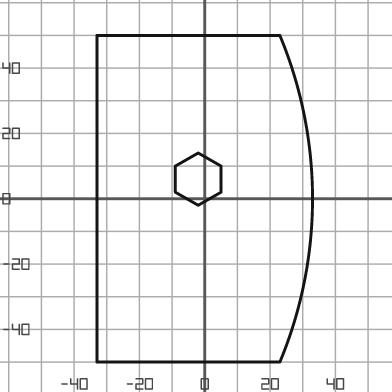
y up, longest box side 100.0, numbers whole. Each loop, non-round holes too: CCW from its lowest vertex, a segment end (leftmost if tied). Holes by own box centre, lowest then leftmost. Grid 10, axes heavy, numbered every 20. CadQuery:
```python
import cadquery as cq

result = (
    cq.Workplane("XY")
    .moveTo(-33.0, -50.0)
    .lineTo(23.0, -50.0)
    .threePointArc((33.0, 0.0), (23.0, 50.0))
    .lineTo(-33.0, 50.0)
    .close()
    .moveTo(-2.0, -2.0)
    .lineTo(5.0, 2.0)
    .lineTo(5.0, 10.0)
    .lineTo(-2.0, 14.0)
    .lineTo(-9.0, 10.0)
    .lineTo(-9.0, 2.0)
    .close()
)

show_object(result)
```